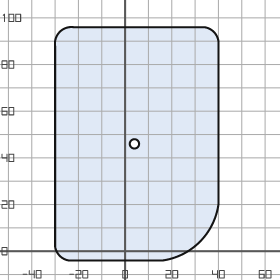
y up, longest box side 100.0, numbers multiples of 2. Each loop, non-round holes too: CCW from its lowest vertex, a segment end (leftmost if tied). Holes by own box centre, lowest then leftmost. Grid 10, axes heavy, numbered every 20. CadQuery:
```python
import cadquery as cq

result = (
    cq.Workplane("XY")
    .moveTo(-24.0, -4.0)
    .lineTo(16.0, -4.0)
    .threePointArc((32.0, 4.0), (40.0, 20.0))
    .lineTo(40.0, 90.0)
    .threePointArc((38.0, 94.0), (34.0, 96.0))
    .lineTo(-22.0, 96.0)
    .threePointArc((-28.0, 94.0), (-30.0, 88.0))
    .lineTo(-30.0, 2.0)
    .threePointArc((-28.0, -2.0), (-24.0, -4.0))
    .close()
    .moveTo(4.0, 46.0)
    .circle(2.0)
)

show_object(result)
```